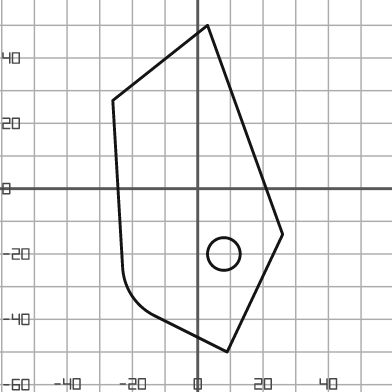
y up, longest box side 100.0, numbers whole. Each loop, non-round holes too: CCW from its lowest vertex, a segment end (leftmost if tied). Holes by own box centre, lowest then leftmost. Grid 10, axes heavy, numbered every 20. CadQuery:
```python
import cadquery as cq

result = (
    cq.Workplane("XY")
    .moveTo(9.0, -50.0)
    .lineTo(26.0, -14.0)
    .lineTo(3.0, 50.0)
    .lineTo(-26.0, 27.0)
    .lineTo(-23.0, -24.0)
    .threePointArc((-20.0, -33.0), (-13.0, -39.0))
    .close()
    .moveTo(8.0, -20.0)
    .circle(5.0)
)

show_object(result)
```